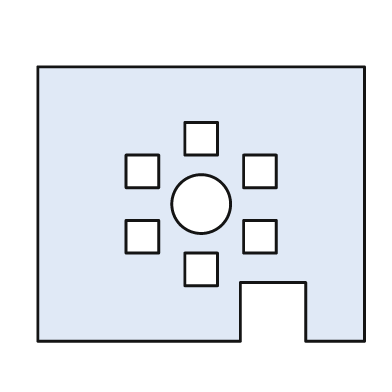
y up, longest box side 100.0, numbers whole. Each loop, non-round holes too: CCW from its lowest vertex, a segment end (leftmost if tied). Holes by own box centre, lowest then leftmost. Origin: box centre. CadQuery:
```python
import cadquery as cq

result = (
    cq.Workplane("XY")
    .moveTo(-50.0, -42.0)
    .lineTo(12.0, -42.0)
    .lineTo(12.0, -24.0)
    .lineTo(32.0, -24.0)
    .lineTo(32.0, -42.0)
    .lineTo(50.0, -42.0)
    .lineTo(50.0, 42.0)
    .lineTo(-50.0, 42.0)
    .close()
    .moveTo(-5.0, -25.0)
    .lineTo(5.0, -25.0)
    .lineTo(5.0, -15.0)
    .lineTo(-5.0, -15.0)
    .close()
    .moveTo(-23.0, -15.0)
    .lineTo(-13.0, -15.0)
    .lineTo(-13.0, -5.0)
    .lineTo(-23.0, -5.0)
    .close()
    .moveTo(13.0, -15.0)
    .lineTo(23.0, -15.0)
    .lineTo(23.0, -5.0)
    .lineTo(13.0, -5.0)
    .close()
    .moveTo(0.0, 0.0)
    .circle(9.0)
    .moveTo(-23.0, 5.0)
    .lineTo(-13.0, 5.0)
    .lineTo(-13.0, 15.0)
    .lineTo(-23.0, 15.0)
    .close()
    .moveTo(13.0, 5.0)
    .lineTo(23.0, 5.0)
    .lineTo(23.0, 15.0)
    .lineTo(13.0, 15.0)
    .close()
    .moveTo(-5.0, 15.0)
    .lineTo(5.0, 15.0)
    .lineTo(5.0, 25.0)
    .lineTo(-5.0, 25.0)
    .close()
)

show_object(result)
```